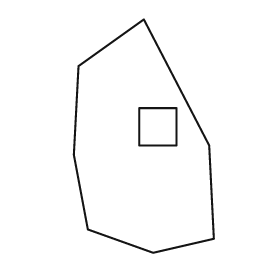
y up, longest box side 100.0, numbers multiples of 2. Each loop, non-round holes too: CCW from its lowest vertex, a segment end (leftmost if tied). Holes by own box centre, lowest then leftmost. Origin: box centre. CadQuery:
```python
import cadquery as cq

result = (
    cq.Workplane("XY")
    .moveTo(4.0, -50.0)
    .lineTo(30.0, -44.0)
    .lineTo(28.0, -4.0)
    .lineTo(0.0, 50.0)
    .lineTo(-28.0, 30.0)
    .lineTo(-30.0, -8.0)
    .lineTo(-24.0, -40.0)
    .close()
    .moveTo(-2.0, -4.0)
    .lineTo(14.0, -4.0)
    .lineTo(14.0, 12.0)
    .lineTo(-2.0, 12.0)
    .close()
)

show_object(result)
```